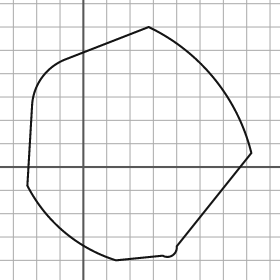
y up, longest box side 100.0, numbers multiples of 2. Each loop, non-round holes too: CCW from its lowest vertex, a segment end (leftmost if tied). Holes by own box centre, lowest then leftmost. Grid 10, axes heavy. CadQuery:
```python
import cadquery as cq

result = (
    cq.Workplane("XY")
    .moveTo(14.0, -40.0)
    .lineTo(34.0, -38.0)
    .threePointArc((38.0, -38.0), (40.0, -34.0))
    .lineTo(72.0, 6.0)
    .threePointArc((56.0, 38.0), (28.0, 60.0))
    .lineTo(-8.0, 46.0)
    .threePointArc((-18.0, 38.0), (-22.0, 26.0))
    .lineTo(-24.0, -8.0)
    .threePointArc((-8.0, -28.0), (14.0, -40.0))
    .close()
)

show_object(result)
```